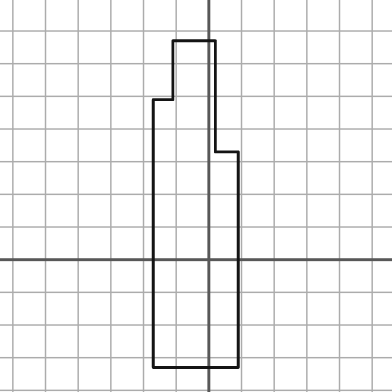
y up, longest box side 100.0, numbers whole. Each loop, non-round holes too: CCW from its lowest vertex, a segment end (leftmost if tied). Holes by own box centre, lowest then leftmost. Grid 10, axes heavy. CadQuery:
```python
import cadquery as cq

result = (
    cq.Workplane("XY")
    .moveTo(-17.0, -33.0)
    .lineTo(9.0, -33.0)
    .lineTo(9.0, 33.0)
    .lineTo(2.0, 33.0)
    .lineTo(2.0, 67.0)
    .lineTo(-11.0, 67.0)
    .lineTo(-11.0, 49.0)
    .lineTo(-17.0, 49.0)
    .close()
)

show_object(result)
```